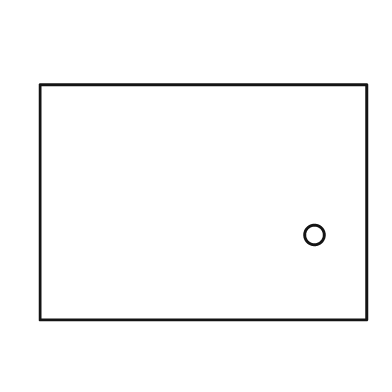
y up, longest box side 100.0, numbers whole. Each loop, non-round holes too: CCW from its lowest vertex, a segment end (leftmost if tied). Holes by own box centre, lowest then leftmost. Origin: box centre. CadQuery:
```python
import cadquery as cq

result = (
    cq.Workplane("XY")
    .moveTo(-50.0, -36.0)
    .lineTo(50.0, -36.0)
    .lineTo(50.0, 36.0)
    .lineTo(-50.0, 36.0)
    .close()
    .moveTo(34.0, -10.0)
    .circle(3.0)
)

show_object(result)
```